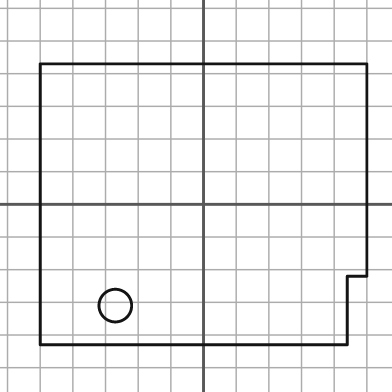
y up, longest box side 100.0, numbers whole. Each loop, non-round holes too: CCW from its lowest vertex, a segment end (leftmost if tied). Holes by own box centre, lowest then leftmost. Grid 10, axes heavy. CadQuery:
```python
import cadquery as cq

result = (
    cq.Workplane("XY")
    .moveTo(-50.0, -43.0)
    .lineTo(44.0, -43.0)
    .lineTo(44.0, -22.0)
    .lineTo(50.0, -22.0)
    .lineTo(50.0, 43.0)
    .lineTo(-50.0, 43.0)
    .close()
    .moveTo(-27.0, -31.0)
    .circle(5.0)
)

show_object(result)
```